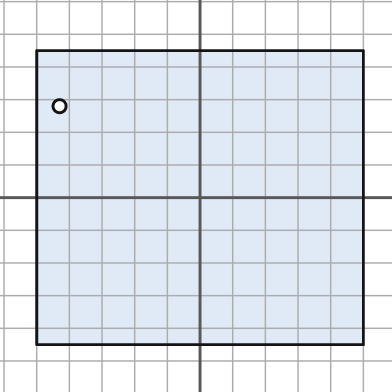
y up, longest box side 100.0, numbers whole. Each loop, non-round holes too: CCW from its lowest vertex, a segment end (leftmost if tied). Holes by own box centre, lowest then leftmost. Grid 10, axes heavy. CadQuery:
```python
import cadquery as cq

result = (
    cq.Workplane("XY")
    .moveTo(-50.0, -45.0)
    .lineTo(50.0, -45.0)
    .lineTo(50.0, 45.0)
    .lineTo(-50.0, 45.0)
    .close()
    .moveTo(-43.0, 28.0)
    .circle(2.0)
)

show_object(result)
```